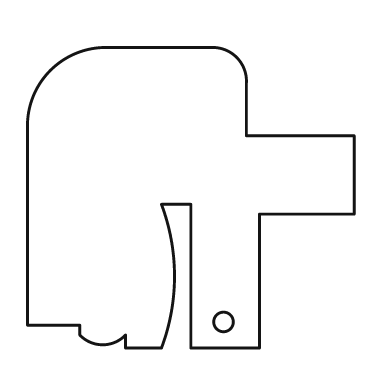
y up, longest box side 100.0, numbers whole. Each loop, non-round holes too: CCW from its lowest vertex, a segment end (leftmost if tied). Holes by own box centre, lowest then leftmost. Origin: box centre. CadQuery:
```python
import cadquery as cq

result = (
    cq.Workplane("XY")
    .moveTo(-20.0, -46.0)
    .lineTo(-9.0, -46.0)
    .threePointArc((-5.0, -24.0), (-9.0, -2.0))
    .lineTo(0.0, -2.0)
    .lineTo(0.0, -46.0)
    .lineTo(21.0, -46.0)
    .lineTo(21.0, -5.0)
    .lineTo(50.0, -5.0)
    .lineTo(50.0, 19.0)
    .lineTo(17.0, 19.0)
    .lineTo(17.0, 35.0)
    .threePointArc((14.0, 43.0), (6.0, 46.0))
    .lineTo(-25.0, 46.0)
    .threePointArc((-43.0, 39.0), (-50.0, 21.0))
    .lineTo(-50.0, -39.0)
    .lineTo(-34.0, -39.0)
    .lineTo(-34.0, -42.0)
    .threePointArc((-27.0, -45.0), (-20.0, -42.0))
    .close()
    .moveTo(10.0, -38.0)
    .circle(3.0)
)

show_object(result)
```